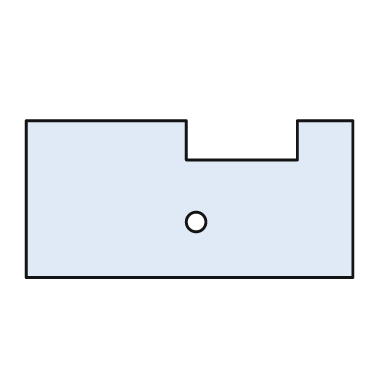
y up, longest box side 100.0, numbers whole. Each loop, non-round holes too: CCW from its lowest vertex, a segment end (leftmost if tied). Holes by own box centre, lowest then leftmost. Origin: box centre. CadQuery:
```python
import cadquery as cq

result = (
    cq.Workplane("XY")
    .moveTo(-50.0, -24.0)
    .lineTo(50.0, -24.0)
    .lineTo(50.0, 24.0)
    .lineTo(33.0, 24.0)
    .lineTo(33.0, 12.0)
    .lineTo(-1.0, 12.0)
    .lineTo(-1.0, 24.0)
    .lineTo(-50.0, 24.0)
    .close()
    .moveTo(2.0, -7.0)
    .circle(3.0)
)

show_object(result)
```